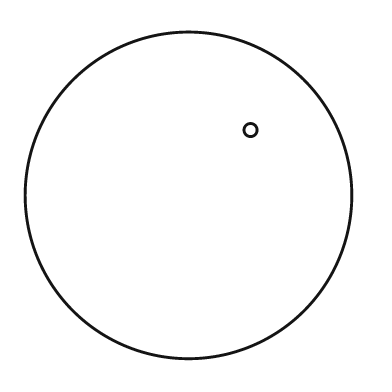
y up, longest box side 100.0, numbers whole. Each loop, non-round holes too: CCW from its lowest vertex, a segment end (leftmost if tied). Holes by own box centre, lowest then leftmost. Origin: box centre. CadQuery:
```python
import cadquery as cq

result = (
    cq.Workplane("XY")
    .moveTo(0.0, 0.0)
    .circle(50.0)
    .moveTo(19.0, 20.0)
    .circle(2.0)
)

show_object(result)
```